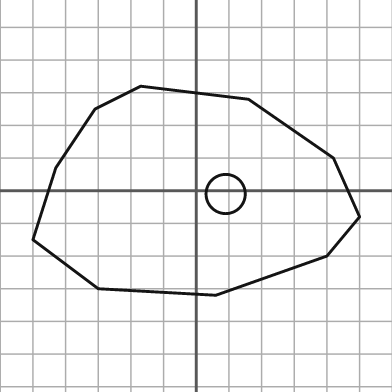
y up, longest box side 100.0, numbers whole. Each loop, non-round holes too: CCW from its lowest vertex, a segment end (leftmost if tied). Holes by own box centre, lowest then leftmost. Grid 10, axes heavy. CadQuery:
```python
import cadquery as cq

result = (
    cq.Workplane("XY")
    .moveTo(6.0, -32.0)
    .lineTo(40.0, -20.0)
    .lineTo(50.0, -8.0)
    .lineTo(42.0, 10.0)
    .lineTo(16.0, 28.0)
    .lineTo(-17.0, 32.0)
    .lineTo(-31.0, 25.0)
    .lineTo(-43.0, 7.0)
    .lineTo(-50.0, -15.0)
    .lineTo(-30.0, -30.0)
    .close()
    .moveTo(9.0, -1.0)
    .circle(6.0)
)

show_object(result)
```